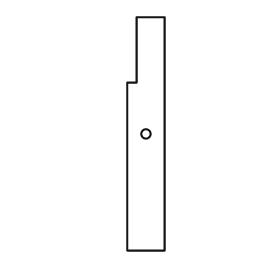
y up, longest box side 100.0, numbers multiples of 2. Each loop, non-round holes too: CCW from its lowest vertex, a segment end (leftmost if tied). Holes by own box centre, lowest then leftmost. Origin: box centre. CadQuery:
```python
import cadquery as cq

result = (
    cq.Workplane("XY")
    .moveTo(-8.0, -50.0)
    .lineTo(8.0, -50.0)
    .lineTo(8.0, 50.0)
    .lineTo(-4.0, 50.0)
    .lineTo(-4.0, 22.0)
    .lineTo(-8.0, 22.0)
    .close()
    .moveTo(0.0, 0.0)
    .circle(2.0)
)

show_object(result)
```